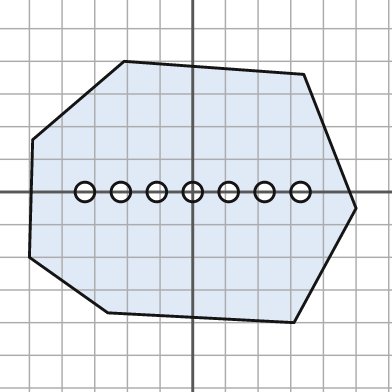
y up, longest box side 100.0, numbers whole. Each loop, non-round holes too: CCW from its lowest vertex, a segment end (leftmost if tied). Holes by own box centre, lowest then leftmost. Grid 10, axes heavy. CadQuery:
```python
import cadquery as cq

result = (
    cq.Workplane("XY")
    .moveTo(31.0, -40.0)
    .lineTo(50.0, -5.0)
    .lineTo(34.0, 36.0)
    .lineTo(-21.0, 40.0)
    .lineTo(-49.0, 16.0)
    .lineTo(-50.0, -20.0)
    .lineTo(-26.0, -37.0)
    .close()
    .moveTo(-33.0, 0.0)
    .circle(3.0)
    .moveTo(-22.0, 0.0)
    .circle(3.0)
    .moveTo(-11.0, 0.0)
    .circle(3.0)
    .moveTo(0.0, 0.0)
    .circle(3.0)
    .moveTo(11.0, 0.0)
    .circle(3.0)
    .moveTo(22.0, 0.0)
    .circle(3.0)
    .moveTo(33.0, 0.0)
    .circle(3.0)
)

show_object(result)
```